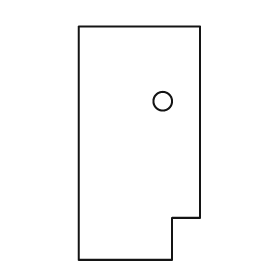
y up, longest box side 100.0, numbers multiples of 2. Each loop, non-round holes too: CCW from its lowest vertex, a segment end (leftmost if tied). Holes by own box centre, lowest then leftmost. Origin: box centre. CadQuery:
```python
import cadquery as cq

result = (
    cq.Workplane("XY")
    .moveTo(-26.0, -50.0)
    .lineTo(14.0, -50.0)
    .lineTo(14.0, -32.0)
    .lineTo(26.0, -32.0)
    .lineTo(26.0, 50.0)
    .lineTo(-26.0, 50.0)
    .close()
    .moveTo(10.0, 18.0)
    .circle(4.0)
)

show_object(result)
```